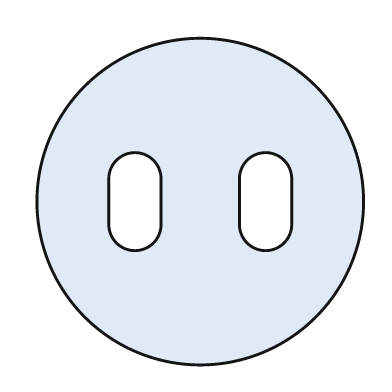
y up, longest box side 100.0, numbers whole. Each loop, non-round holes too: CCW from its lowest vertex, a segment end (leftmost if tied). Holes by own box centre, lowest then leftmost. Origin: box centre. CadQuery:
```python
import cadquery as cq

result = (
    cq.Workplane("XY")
    .moveTo(0.0, 0.0)
    .circle(50.0)
    .moveTo(-28.0, -7.0)
    .threePointArc((-20.0, -15.0), (-12.0, -7.0))
    .lineTo(-12.0, 7.0)
    .threePointArc((-20.0, 15.0), (-28.0, 7.0))
    .close()
    .moveTo(12.0, -7.0)
    .threePointArc((20.0, -15.0), (28.0, -7.0))
    .lineTo(28.0, 7.0)
    .threePointArc((20.0, 15.0), (12.0, 7.0))
    .close()
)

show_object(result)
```